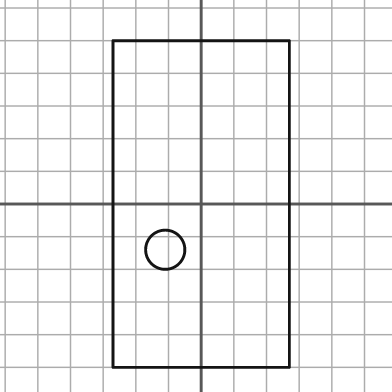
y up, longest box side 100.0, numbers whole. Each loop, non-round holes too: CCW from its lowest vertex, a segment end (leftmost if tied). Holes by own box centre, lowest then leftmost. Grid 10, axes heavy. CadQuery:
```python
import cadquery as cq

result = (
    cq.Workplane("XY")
    .moveTo(-27.0, -50.0)
    .lineTo(27.0, -50.0)
    .lineTo(27.0, 50.0)
    .lineTo(-27.0, 50.0)
    .close()
    .moveTo(-11.0, -14.0)
    .circle(6.0)
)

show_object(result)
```